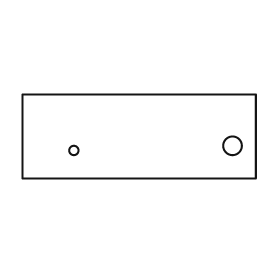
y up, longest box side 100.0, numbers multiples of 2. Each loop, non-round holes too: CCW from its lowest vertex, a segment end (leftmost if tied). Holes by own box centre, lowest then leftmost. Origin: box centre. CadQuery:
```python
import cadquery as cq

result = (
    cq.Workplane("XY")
    .moveTo(-50.0, -18.0)
    .lineTo(50.0, -18.0)
    .lineTo(50.0, 18.0)
    .lineTo(-50.0, 18.0)
    .close()
    .moveTo(-28.0, -6.0)
    .circle(2.0)
    .moveTo(40.0, -4.0)
    .circle(4.0)
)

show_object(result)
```